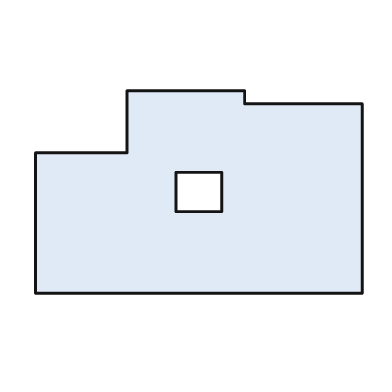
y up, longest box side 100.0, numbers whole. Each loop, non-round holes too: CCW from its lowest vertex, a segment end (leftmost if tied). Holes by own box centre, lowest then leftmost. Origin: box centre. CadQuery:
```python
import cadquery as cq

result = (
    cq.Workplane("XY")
    .moveTo(-50.0, -31.0)
    .lineTo(50.0, -31.0)
    .lineTo(50.0, 27.0)
    .lineTo(14.0, 27.0)
    .lineTo(14.0, 31.0)
    .lineTo(-22.0, 31.0)
    .lineTo(-22.0, 12.0)
    .lineTo(-50.0, 12.0)
    .close()
    .moveTo(-7.0, -6.0)
    .lineTo(7.0, -6.0)
    .lineTo(7.0, 6.0)
    .lineTo(-7.0, 6.0)
    .close()
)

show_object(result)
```